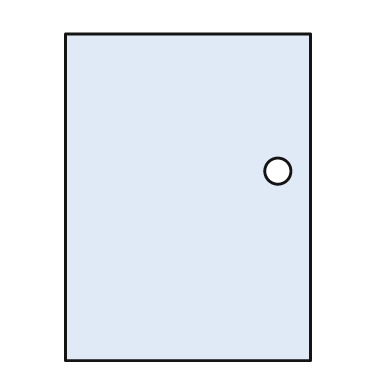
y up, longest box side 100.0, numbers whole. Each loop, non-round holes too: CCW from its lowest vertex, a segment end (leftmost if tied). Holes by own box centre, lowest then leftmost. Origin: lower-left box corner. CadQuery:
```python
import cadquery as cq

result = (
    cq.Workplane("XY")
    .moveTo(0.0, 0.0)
    .lineTo(75.0, 0.0)
    .lineTo(75.0, 100.0)
    .lineTo(0.0, 100.0)
    .close()
    .moveTo(65.0, 58.0)
    .circle(4.0)
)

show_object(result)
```